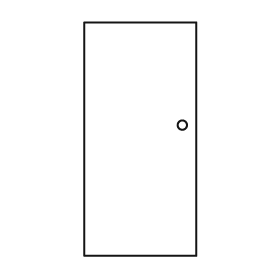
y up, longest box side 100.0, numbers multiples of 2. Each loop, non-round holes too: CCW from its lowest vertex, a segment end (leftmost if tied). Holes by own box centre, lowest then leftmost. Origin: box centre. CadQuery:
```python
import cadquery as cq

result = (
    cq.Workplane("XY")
    .moveTo(-24.0, -50.0)
    .lineTo(24.0, -50.0)
    .lineTo(24.0, 50.0)
    .lineTo(-24.0, 50.0)
    .close()
    .moveTo(18.0, 6.0)
    .circle(2.0)
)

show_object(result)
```